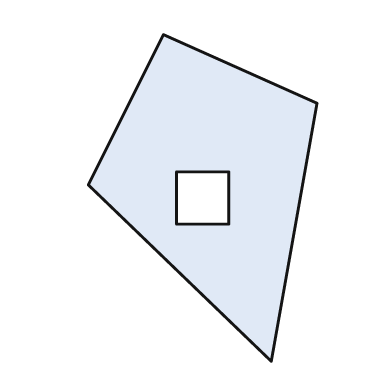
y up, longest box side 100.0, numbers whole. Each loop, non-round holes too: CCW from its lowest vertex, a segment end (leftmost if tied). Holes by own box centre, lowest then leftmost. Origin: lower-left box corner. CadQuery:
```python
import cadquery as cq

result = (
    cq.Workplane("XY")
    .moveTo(56.0, 0.0)
    .lineTo(70.0, 79.0)
    .lineTo(23.0, 100.0)
    .lineTo(0.0, 54.0)
    .close()
    .moveTo(27.0, 42.0)
    .lineTo(43.0, 42.0)
    .lineTo(43.0, 58.0)
    .lineTo(27.0, 58.0)
    .close()
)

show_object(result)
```